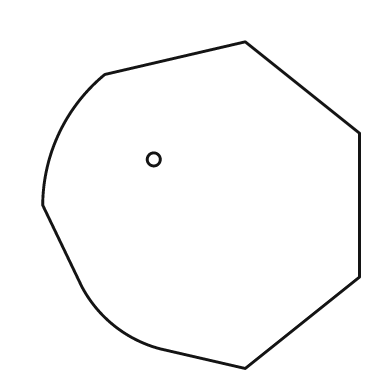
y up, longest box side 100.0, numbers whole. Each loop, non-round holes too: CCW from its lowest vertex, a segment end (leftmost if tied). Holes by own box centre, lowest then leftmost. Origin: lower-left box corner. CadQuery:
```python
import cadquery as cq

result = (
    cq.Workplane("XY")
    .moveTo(62.0, 0.0)
    .lineTo(97.0, 28.0)
    .lineTo(97.0, 72.0)
    .lineTo(62.0, 100.0)
    .lineTo(19.0, 90.0)
    .threePointArc((5.0, 72.0), (0.0, 50.0))
    .lineTo(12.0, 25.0)
    .threePointArc((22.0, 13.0), (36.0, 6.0))
    .close()
    .moveTo(34.0, 64.0)
    .circle(2.0)
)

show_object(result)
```